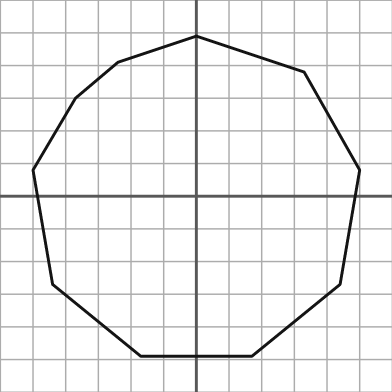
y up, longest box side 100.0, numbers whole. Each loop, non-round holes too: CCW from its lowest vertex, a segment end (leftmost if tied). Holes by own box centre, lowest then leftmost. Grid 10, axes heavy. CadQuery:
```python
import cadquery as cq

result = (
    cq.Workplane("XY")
    .moveTo(-17.0, -49.0)
    .lineTo(17.0, -49.0)
    .lineTo(44.0, -27.0)
    .lineTo(50.0, 8.0)
    .lineTo(33.0, 38.0)
    .lineTo(0.0, 49.0)
    .lineTo(-24.0, 41.0)
    .lineTo(-37.0, 30.0)
    .lineTo(-50.0, 8.0)
    .lineTo(-44.0, -27.0)
    .close()
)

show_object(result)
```